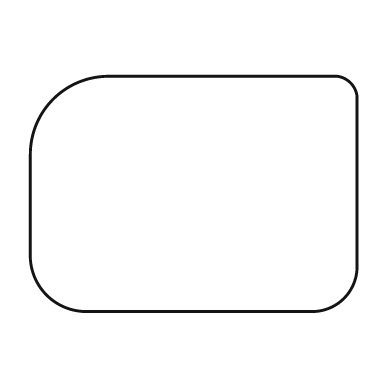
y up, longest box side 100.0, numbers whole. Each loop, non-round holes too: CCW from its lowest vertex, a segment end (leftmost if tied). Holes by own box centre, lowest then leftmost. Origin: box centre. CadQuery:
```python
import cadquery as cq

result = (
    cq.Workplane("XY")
    .moveTo(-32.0, -36.0)
    .lineTo(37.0, -36.0)
    .threePointArc((46.0, -32.0), (50.0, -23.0))
    .lineTo(50.0, 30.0)
    .threePointArc((48.0, 34.0), (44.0, 36.0))
    .lineTo(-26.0, 36.0)
    .threePointArc((-43.0, 29.0), (-50.0, 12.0))
    .lineTo(-50.0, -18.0)
    .threePointArc((-45.0, -31.0), (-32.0, -36.0))
    .close()
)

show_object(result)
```